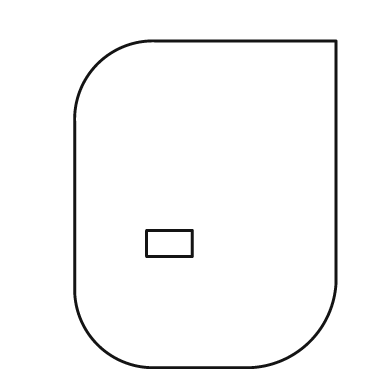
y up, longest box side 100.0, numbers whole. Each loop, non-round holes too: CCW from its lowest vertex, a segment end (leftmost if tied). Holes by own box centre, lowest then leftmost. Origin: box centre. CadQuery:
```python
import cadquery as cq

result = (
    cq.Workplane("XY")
    .moveTo(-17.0, -50.0)
    .lineTo(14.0, -50.0)
    .threePointArc((32.0, -42.0), (40.0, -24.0))
    .lineTo(40.0, 50.0)
    .lineTo(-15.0, 50.0)
    .threePointArc((-33.0, 43.0), (-40.0, 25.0))
    .lineTo(-40.0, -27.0)
    .threePointArc((-33.0, -43.0), (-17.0, -50.0))
    .close()
    .moveTo(-18.0, -16.0)
    .lineTo(-4.0, -16.0)
    .lineTo(-4.0, -8.0)
    .lineTo(-18.0, -8.0)
    .close()
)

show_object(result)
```